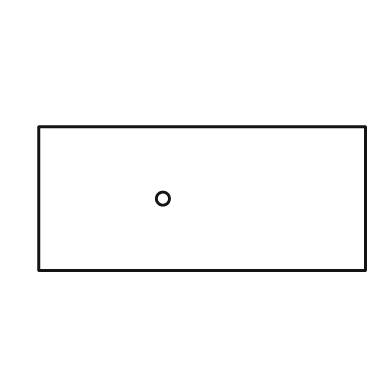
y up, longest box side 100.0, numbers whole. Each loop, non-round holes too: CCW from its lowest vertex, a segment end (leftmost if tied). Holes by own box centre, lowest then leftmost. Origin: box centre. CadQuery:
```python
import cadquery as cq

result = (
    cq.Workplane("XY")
    .moveTo(-50.0, -22.0)
    .lineTo(50.0, -22.0)
    .lineTo(50.0, 22.0)
    .lineTo(-50.0, 22.0)
    .close()
    .moveTo(-12.0, 0.0)
    .circle(2.0)
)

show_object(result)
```